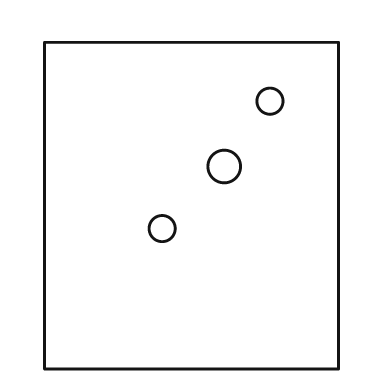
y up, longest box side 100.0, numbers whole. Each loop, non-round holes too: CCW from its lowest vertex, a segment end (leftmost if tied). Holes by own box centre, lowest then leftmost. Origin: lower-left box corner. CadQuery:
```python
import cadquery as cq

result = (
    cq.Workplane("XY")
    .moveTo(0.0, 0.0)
    .lineTo(90.0, 0.0)
    .lineTo(90.0, 100.0)
    .lineTo(0.0, 100.0)
    .close()
    .moveTo(36.0, 43.0)
    .circle(4.0)
    .moveTo(55.0, 62.0)
    .circle(5.0)
    .moveTo(69.0, 82.0)
    .circle(4.0)
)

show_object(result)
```